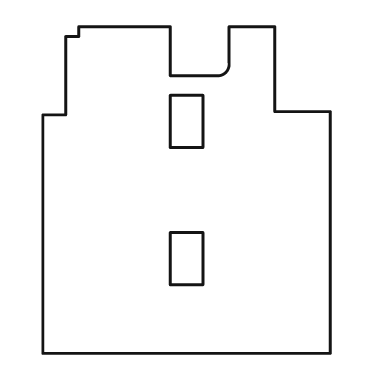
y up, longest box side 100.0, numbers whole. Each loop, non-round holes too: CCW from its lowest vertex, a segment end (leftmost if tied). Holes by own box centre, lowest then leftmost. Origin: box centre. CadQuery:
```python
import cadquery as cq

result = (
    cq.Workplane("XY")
    .moveTo(-44.0, -50.0)
    .lineTo(44.0, -50.0)
    .lineTo(44.0, 24.0)
    .lineTo(27.0, 24.0)
    .lineTo(27.0, 50.0)
    .lineTo(13.0, 50.0)
    .lineTo(13.0, 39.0)
    .threePointArc((12.0, 36.0), (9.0, 35.0))
    .lineTo(-5.0, 35.0)
    .lineTo(-5.0, 50.0)
    .lineTo(-33.0, 50.0)
    .lineTo(-33.0, 47.0)
    .lineTo(-37.0, 47.0)
    .lineTo(-37.0, 23.0)
    .lineTo(-44.0, 23.0)
    .close()
    .moveTo(-5.0, -29.0)
    .lineTo(5.0, -29.0)
    .lineTo(5.0, -13.0)
    .lineTo(-5.0, -13.0)
    .close()
    .moveTo(-5.0, 13.0)
    .lineTo(5.0, 13.0)
    .lineTo(5.0, 29.0)
    .lineTo(-5.0, 29.0)
    .close()
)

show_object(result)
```